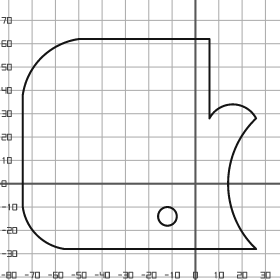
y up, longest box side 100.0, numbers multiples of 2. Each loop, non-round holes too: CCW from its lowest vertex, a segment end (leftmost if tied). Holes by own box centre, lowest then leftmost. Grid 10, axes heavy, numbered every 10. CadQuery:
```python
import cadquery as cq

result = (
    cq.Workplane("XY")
    .moveTo(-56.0, -28.0)
    .lineTo(26.0, -28.0)
    .threePointArc((14.0, 0.0), (26.0, 28.0))
    .threePointArc((16.0, 34.0), (6.0, 28.0))
    .lineTo(6.0, 62.0)
    .lineTo(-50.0, 62.0)
    .threePointArc((-66.0, 54.0), (-74.0, 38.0))
    .lineTo(-74.0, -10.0)
    .threePointArc((-68.0, -22.0), (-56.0, -28.0))
    .close()
    .moveTo(-12.0, -14.0)
    .circle(4.0)
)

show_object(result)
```